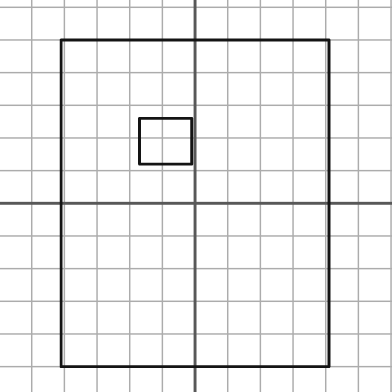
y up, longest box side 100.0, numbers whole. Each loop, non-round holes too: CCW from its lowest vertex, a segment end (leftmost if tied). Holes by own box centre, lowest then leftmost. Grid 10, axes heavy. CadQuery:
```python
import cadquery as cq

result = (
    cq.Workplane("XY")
    .moveTo(-41.0, -50.0)
    .lineTo(41.0, -50.0)
    .lineTo(41.0, 50.0)
    .lineTo(-41.0, 50.0)
    .close()
    .moveTo(-17.0, 12.0)
    .lineTo(-1.0, 12.0)
    .lineTo(-1.0, 26.0)
    .lineTo(-17.0, 26.0)
    .close()
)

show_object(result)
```